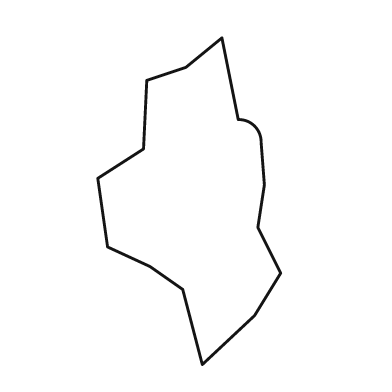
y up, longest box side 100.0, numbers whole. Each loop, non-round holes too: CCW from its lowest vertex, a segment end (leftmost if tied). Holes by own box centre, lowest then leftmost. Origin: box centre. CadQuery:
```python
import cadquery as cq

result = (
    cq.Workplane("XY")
    .moveTo(4.0, -50.0)
    .lineTo(20.0, -35.0)
    .lineTo(28.0, -22.0)
    .lineTo(21.0, -8.0)
    .lineTo(23.0, 5.0)
    .lineTo(22.0, 18.0)
    .threePointArc((20.0, 23.0), (15.0, 25.0))
    .lineTo(10.0, 50.0)
    .lineTo(-1.0, 41.0)
    .lineTo(-13.0, 37.0)
    .lineTo(-14.0, 16.0)
    .lineTo(-28.0, 7.0)
    .lineTo(-25.0, -14.0)
    .lineTo(-12.0, -20.0)
    .lineTo(-2.0, -27.0)
    .close()
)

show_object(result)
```